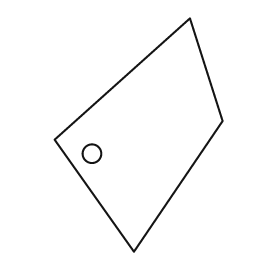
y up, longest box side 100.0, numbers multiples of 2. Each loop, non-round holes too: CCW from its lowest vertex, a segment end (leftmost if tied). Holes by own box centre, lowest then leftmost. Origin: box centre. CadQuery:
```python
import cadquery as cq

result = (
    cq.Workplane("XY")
    .moveTo(-2.0, -50.0)
    .lineTo(36.0, 6.0)
    .lineTo(22.0, 50.0)
    .lineTo(-36.0, -2.0)
    .close()
    .moveTo(-20.0, -8.0)
    .circle(4.0)
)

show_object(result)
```